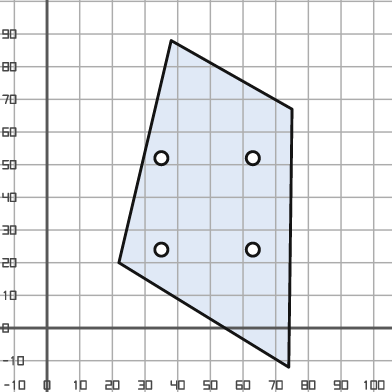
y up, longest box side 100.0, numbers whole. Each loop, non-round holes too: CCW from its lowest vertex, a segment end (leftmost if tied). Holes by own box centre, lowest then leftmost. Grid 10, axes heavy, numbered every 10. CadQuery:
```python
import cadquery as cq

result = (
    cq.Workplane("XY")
    .moveTo(74.0, -12.0)
    .lineTo(75.0, 67.0)
    .lineTo(38.0, 88.0)
    .lineTo(22.0, 20.0)
    .close()
    .moveTo(35.0, 24.0)
    .circle(2.0)
    .moveTo(63.0, 24.0)
    .circle(2.0)
    .moveTo(35.0, 52.0)
    .circle(2.0)
    .moveTo(63.0, 52.0)
    .circle(2.0)
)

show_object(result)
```